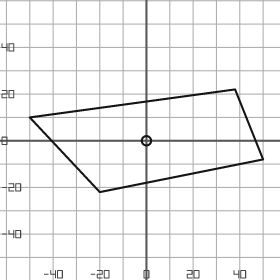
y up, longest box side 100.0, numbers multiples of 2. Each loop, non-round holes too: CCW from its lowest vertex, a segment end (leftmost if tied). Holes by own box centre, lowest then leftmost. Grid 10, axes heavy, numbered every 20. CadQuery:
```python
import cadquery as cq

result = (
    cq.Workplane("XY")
    .moveTo(-20.0, -22.0)
    .lineTo(50.0, -8.0)
    .lineTo(38.0, 22.0)
    .lineTo(-50.0, 10.0)
    .close()
    .moveTo(0.0, 0.0)
    .circle(2.0)
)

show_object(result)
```